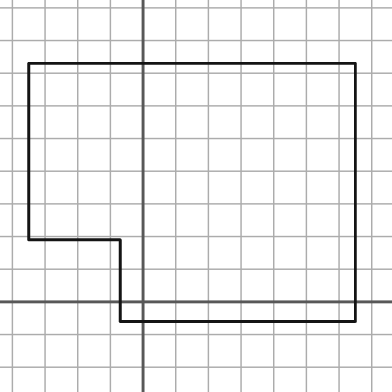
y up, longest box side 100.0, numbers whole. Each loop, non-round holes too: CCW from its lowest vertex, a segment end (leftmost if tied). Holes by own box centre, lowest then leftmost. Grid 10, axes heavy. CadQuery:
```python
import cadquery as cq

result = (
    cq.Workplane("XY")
    .moveTo(-7.0, -6.0)
    .lineTo(65.0, -6.0)
    .lineTo(65.0, 73.0)
    .lineTo(-35.0, 73.0)
    .lineTo(-35.0, 19.0)
    .lineTo(-7.0, 19.0)
    .close()
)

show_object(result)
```